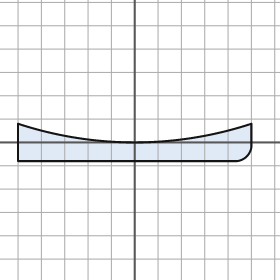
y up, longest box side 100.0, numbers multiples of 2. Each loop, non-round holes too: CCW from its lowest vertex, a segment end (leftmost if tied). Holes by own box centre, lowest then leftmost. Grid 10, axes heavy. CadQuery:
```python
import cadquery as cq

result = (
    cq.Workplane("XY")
    .moveTo(-50.0, -8.0)
    .lineTo(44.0, -8.0)
    .threePointArc((48.0, -6.0), (50.0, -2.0))
    .lineTo(50.0, 8.0)
    .threePointArc((0.0, 0.0), (-50.0, 8.0))
    .close()
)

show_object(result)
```